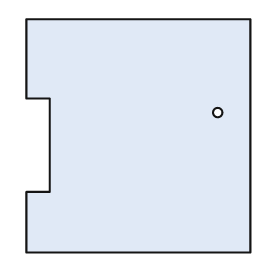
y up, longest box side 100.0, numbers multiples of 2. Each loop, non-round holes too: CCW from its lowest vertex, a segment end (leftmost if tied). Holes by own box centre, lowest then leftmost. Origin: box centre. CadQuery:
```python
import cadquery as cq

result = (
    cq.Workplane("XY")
    .moveTo(-48.0, -50.0)
    .lineTo(48.0, -50.0)
    .lineTo(48.0, 50.0)
    .lineTo(-48.0, 50.0)
    .lineTo(-48.0, 16.0)
    .lineTo(-38.0, 16.0)
    .lineTo(-38.0, -24.0)
    .lineTo(-48.0, -24.0)
    .close()
    .moveTo(34.0, 10.0)
    .circle(2.0)
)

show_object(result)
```